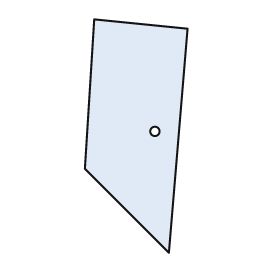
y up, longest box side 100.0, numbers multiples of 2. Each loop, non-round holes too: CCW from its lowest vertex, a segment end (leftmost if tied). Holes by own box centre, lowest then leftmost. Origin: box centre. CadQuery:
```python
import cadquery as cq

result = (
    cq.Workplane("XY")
    .moveTo(14.0, -50.0)
    .lineTo(22.0, 46.0)
    .lineTo(-18.0, 50.0)
    .lineTo(-22.0, -14.0)
    .close()
    .moveTo(8.0, 2.0)
    .circle(2.0)
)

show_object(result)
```